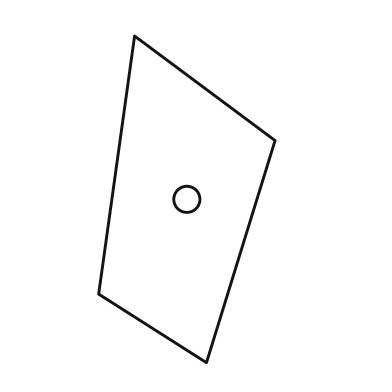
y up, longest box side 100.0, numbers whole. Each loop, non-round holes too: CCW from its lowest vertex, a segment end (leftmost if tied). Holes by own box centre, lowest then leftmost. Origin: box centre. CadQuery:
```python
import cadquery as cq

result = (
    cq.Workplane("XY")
    .moveTo(6.0, -50.0)
    .lineTo(27.0, 18.0)
    .lineTo(-16.0, 50.0)
    .lineTo(-27.0, -29.0)
    .close()
    .moveTo(0.0, 0.0)
    .circle(4.0)
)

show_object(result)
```